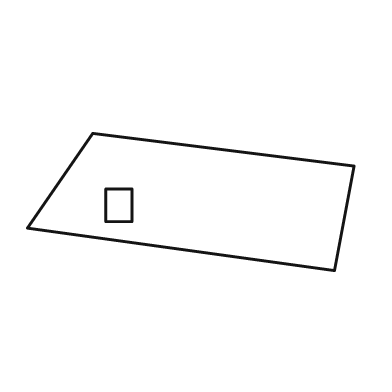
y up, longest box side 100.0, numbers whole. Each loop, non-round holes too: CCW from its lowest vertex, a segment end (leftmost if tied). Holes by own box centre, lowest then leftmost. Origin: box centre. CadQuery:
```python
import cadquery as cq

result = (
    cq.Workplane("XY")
    .moveTo(44.0, -21.0)
    .lineTo(50.0, 11.0)
    .lineTo(-30.0, 21.0)
    .lineTo(-50.0, -8.0)
    .close()
    .moveTo(-26.0, -6.0)
    .lineTo(-18.0, -6.0)
    .lineTo(-18.0, 4.0)
    .lineTo(-26.0, 4.0)
    .close()
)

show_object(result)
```